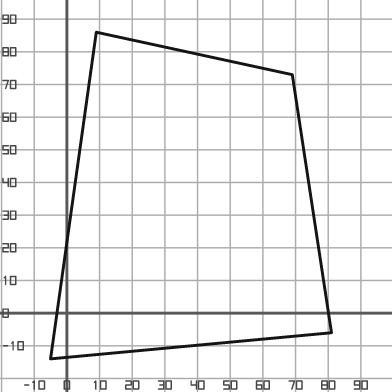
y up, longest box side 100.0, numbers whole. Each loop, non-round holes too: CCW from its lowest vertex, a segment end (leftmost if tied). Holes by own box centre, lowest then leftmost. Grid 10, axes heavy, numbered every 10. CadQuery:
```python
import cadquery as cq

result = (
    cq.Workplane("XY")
    .moveTo(-5.0, -14.0)
    .lineTo(81.0, -6.0)
    .lineTo(69.0, 73.0)
    .lineTo(9.0, 86.0)
    .close()
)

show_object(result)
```